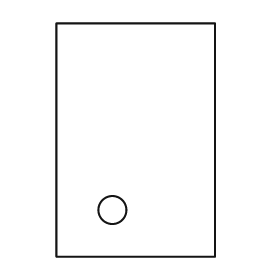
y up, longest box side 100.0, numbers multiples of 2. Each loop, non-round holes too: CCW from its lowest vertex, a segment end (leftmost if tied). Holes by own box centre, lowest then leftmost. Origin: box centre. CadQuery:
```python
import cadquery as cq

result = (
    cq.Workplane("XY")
    .moveTo(-34.0, -50.0)
    .lineTo(34.0, -50.0)
    .lineTo(34.0, 50.0)
    .lineTo(-34.0, 50.0)
    .close()
    .moveTo(-10.0, -30.0)
    .circle(6.0)
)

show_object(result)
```